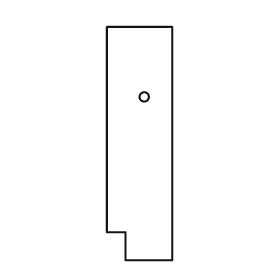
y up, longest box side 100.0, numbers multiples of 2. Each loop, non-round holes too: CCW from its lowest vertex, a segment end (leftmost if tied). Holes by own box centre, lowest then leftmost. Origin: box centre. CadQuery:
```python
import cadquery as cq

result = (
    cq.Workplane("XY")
    .moveTo(-6.0, -50.0)
    .lineTo(14.0, -50.0)
    .lineTo(14.0, 50.0)
    .lineTo(-14.0, 50.0)
    .lineTo(-14.0, -38.0)
    .lineTo(-6.0, -38.0)
    .close()
    .moveTo(2.0, 20.0)
    .circle(2.0)
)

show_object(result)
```